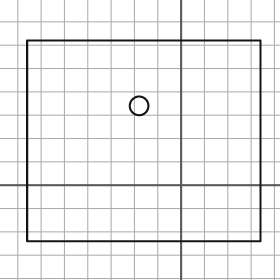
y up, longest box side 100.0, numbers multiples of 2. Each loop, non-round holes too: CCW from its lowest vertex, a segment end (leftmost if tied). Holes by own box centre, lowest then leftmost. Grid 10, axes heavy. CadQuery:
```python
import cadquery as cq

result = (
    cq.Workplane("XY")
    .moveTo(-66.0, -24.0)
    .lineTo(34.0, -24.0)
    .lineTo(34.0, 62.0)
    .lineTo(-66.0, 62.0)
    .close()
    .moveTo(-18.0, 34.0)
    .circle(4.0)
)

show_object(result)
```